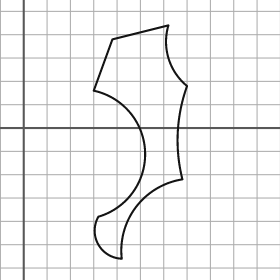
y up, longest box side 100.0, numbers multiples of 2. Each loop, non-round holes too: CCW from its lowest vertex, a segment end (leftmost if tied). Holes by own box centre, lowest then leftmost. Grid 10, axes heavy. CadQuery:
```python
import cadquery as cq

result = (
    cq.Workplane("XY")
    .moveTo(42.0, -56.0)
    .threePointArc((48.0, -34.0), (68.0, -22.0))
    .threePointArc((66.0, -2.0), (70.0, 18.0))
    .threePointArc((62.0, 30.0), (62.0, 44.0))
    .lineTo(38.0, 38.0)
    .lineTo(30.0, 16.0)
    .threePointArc((52.0, -10.0), (32.0, -38.0))
    .threePointArc((32.0, -50.0), (42.0, -56.0))
    .close()
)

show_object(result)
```